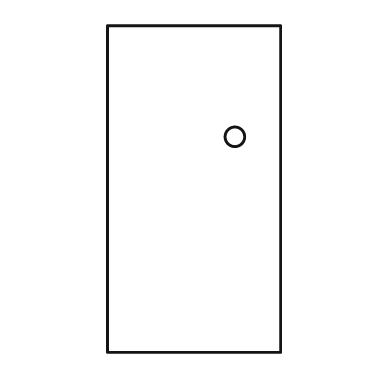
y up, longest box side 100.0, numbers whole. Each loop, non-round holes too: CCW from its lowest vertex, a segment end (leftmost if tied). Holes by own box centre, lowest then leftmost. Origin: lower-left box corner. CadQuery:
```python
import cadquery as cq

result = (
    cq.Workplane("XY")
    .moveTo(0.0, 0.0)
    .lineTo(53.0, 0.0)
    .lineTo(53.0, 100.0)
    .lineTo(0.0, 100.0)
    .close()
    .moveTo(39.0, 66.0)
    .circle(3.0)
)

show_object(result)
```